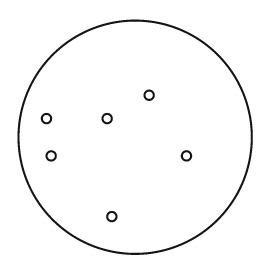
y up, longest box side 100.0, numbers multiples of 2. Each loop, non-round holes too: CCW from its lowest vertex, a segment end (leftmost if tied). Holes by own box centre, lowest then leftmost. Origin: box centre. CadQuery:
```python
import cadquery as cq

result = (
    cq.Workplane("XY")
    .moveTo(0.0, 0.0)
    .circle(50.0)
    .moveTo(-10.0, -34.0)
    .circle(2.0)
    .moveTo(-36.0, -8.0)
    .circle(2.0)
    .moveTo(22.0, -8.0)
    .circle(2.0)
    .moveTo(-38.0, 8.0)
    .circle(2.0)
    .moveTo(-12.0, 8.0)
    .circle(2.0)
    .moveTo(6.0, 18.0)
    .circle(2.0)
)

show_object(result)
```